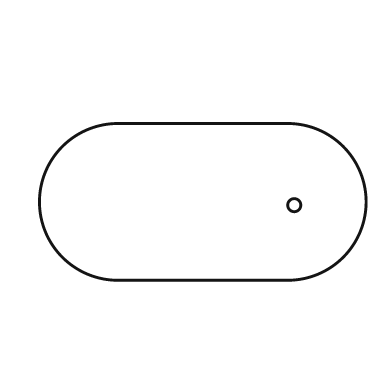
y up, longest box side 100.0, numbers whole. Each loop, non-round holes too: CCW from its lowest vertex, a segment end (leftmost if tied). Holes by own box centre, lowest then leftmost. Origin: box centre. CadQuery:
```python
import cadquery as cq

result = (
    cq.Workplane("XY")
    .moveTo(-26.0, -24.0)
    .lineTo(26.0, -24.0)
    .threePointArc((50.0, 0.0), (26.0, 24.0))
    .lineTo(-26.0, 24.0)
    .threePointArc((-50.0, 0.0), (-26.0, -24.0))
    .close()
    .moveTo(28.0, -1.0)
    .circle(2.0)
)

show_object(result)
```